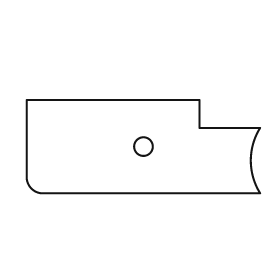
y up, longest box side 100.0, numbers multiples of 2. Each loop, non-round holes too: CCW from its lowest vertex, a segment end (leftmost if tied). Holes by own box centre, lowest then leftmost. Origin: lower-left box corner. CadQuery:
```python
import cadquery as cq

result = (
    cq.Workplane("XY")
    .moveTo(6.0, 0.0)
    .lineTo(100.0, 0.0)
    .threePointArc((96.0, 14.0), (100.0, 28.0))
    .lineTo(74.0, 28.0)
    .lineTo(74.0, 40.0)
    .lineTo(0.0, 40.0)
    .lineTo(0.0, 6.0)
    .threePointArc((2.0, 2.0), (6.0, 0.0))
    .close()
    .moveTo(50.0, 20.0)
    .circle(4.0)
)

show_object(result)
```